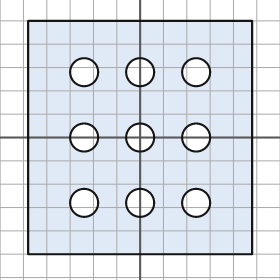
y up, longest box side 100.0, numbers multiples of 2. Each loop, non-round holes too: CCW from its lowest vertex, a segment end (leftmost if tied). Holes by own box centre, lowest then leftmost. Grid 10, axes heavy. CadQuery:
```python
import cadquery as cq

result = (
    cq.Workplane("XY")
    .moveTo(-48.0, -50.0)
    .lineTo(48.0, -50.0)
    .lineTo(48.0, 50.0)
    .lineTo(-48.0, 50.0)
    .close()
    .moveTo(-24.0, -28.0)
    .circle(6.0)
    .moveTo(0.0, -28.0)
    .circle(6.0)
    .moveTo(24.0, -28.0)
    .circle(6.0)
    .moveTo(-24.0, 0.0)
    .circle(6.0)
    .moveTo(0.0, 0.0)
    .circle(6.0)
    .moveTo(24.0, 0.0)
    .circle(6.0)
    .moveTo(-24.0, 28.0)
    .circle(6.0)
    .moveTo(0.0, 28.0)
    .circle(6.0)
    .moveTo(24.0, 28.0)
    .circle(6.0)
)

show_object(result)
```